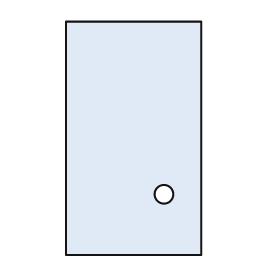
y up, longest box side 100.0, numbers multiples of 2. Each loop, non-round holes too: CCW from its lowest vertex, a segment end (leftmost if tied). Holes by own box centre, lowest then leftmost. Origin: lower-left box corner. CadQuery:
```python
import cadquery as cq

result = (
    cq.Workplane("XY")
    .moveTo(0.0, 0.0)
    .lineTo(58.0, 0.0)
    .lineTo(58.0, 100.0)
    .lineTo(0.0, 100.0)
    .close()
    .moveTo(42.0, 26.0)
    .circle(4.0)
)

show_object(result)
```